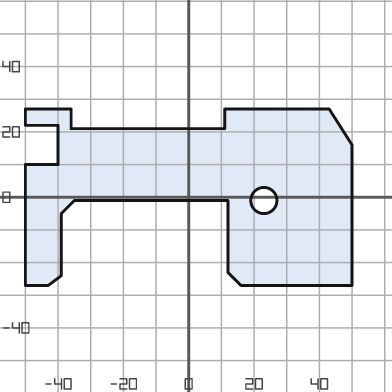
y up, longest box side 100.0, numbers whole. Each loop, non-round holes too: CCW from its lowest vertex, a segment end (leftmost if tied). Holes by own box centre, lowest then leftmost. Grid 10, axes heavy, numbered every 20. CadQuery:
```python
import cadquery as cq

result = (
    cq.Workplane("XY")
    .moveTo(-50.0, -27.0)
    .lineTo(-43.0, -27.0)
    .lineTo(-39.0, -24.0)
    .lineTo(-39.0, -5.0)
    .lineTo(-35.0, -1.0)
    .lineTo(12.0, -1.0)
    .lineTo(12.0, -23.0)
    .lineTo(16.0, -27.0)
    .lineTo(50.0, -27.0)
    .lineTo(50.0, 16.0)
    .lineTo(43.0, 27.0)
    .lineTo(11.0, 27.0)
    .lineTo(11.0, 21.0)
    .lineTo(-36.0, 21.0)
    .lineTo(-36.0, 27.0)
    .lineTo(-50.0, 27.0)
    .lineTo(-50.0, 22.0)
    .lineTo(-40.0, 22.0)
    .lineTo(-40.0, 10.0)
    .lineTo(-50.0, 10.0)
    .close()
    .moveTo(23.0, -1.0)
    .circle(4.0)
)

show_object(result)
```